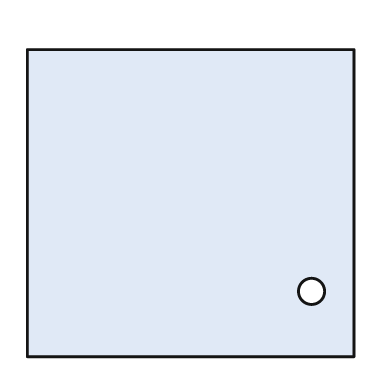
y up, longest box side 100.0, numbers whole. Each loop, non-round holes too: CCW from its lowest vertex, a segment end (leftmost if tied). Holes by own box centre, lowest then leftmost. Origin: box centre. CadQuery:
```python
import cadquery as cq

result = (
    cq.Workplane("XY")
    .moveTo(-50.0, -47.0)
    .lineTo(50.0, -47.0)
    .lineTo(50.0, 47.0)
    .lineTo(-50.0, 47.0)
    .close()
    .moveTo(37.0, -27.0)
    .circle(4.0)
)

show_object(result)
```